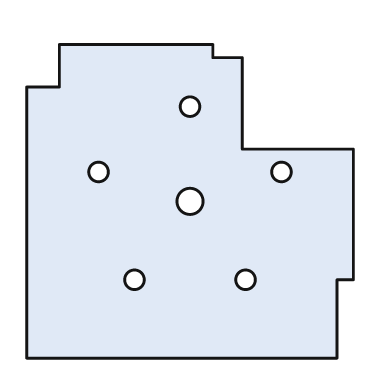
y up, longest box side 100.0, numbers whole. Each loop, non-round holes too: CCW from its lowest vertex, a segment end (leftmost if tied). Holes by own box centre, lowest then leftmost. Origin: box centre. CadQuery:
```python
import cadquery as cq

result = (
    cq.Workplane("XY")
    .moveTo(-50.0, -48.0)
    .lineTo(45.0, -48.0)
    .lineTo(45.0, -24.0)
    .lineTo(50.0, -24.0)
    .lineTo(50.0, 16.0)
    .lineTo(16.0, 16.0)
    .lineTo(16.0, 44.0)
    .lineTo(7.0, 44.0)
    .lineTo(7.0, 48.0)
    .lineTo(-40.0, 48.0)
    .lineTo(-40.0, 35.0)
    .lineTo(-50.0, 35.0)
    .close()
    .moveTo(-17.0, -24.0)
    .circle(3.0)
    .moveTo(17.0, -24.0)
    .circle(3.0)
    .moveTo(0.0, 0.0)
    .circle(4.0)
    .moveTo(-28.0, 9.0)
    .circle(3.0)
    .moveTo(28.0, 9.0)
    .circle(3.0)
    .moveTo(0.0, 29.0)
    .circle(3.0)
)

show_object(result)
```